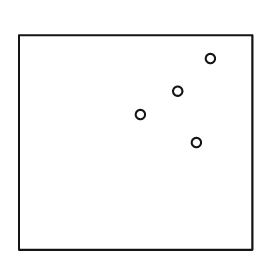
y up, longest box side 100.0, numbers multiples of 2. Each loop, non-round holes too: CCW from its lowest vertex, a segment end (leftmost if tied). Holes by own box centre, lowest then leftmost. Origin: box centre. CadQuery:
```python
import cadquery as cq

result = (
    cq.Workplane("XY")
    .moveTo(-50.0, -46.0)
    .lineTo(50.0, -46.0)
    .lineTo(50.0, 46.0)
    .lineTo(-50.0, 46.0)
    .close()
    .moveTo(26.0, 0.0)
    .circle(2.0)
    .moveTo(2.0, 12.0)
    .circle(2.0)
    .moveTo(18.0, 22.0)
    .circle(2.0)
    .moveTo(32.0, 36.0)
    .circle(2.0)
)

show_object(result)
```